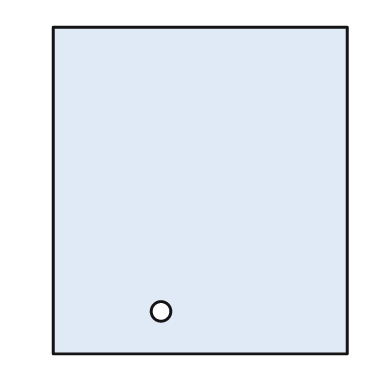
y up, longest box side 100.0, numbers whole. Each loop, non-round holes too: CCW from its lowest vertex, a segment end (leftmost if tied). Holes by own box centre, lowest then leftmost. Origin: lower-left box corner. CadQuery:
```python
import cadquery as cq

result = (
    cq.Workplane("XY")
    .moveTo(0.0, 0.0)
    .lineTo(90.0, 0.0)
    .lineTo(90.0, 100.0)
    .lineTo(0.0, 100.0)
    .close()
    .moveTo(33.0, 13.0)
    .circle(3.0)
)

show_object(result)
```